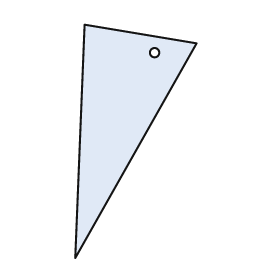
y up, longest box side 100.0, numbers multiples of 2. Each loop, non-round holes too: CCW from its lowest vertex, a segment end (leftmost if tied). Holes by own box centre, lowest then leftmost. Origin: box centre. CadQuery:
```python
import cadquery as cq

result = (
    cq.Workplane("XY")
    .moveTo(-26.0, -50.0)
    .lineTo(26.0, 42.0)
    .lineTo(-22.0, 50.0)
    .close()
    .moveTo(8.0, 38.0)
    .circle(2.0)
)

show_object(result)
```